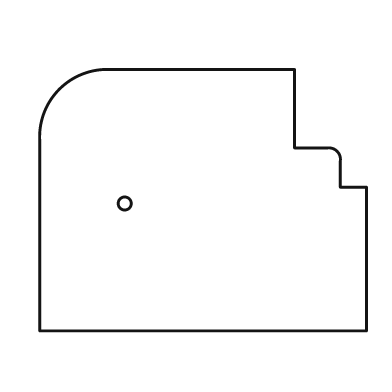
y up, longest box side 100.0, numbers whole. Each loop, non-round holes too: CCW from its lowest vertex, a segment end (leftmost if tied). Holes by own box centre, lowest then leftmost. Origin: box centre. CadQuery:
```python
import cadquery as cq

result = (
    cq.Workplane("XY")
    .moveTo(-50.0, -40.0)
    .lineTo(50.0, -40.0)
    .lineTo(50.0, 4.0)
    .lineTo(42.0, 4.0)
    .lineTo(42.0, 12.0)
    .threePointArc((41.0, 15.0), (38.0, 16.0))
    .lineTo(28.0, 16.0)
    .lineTo(28.0, 40.0)
    .lineTo(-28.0, 40.0)
    .threePointArc((-44.0, 34.0), (-50.0, 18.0))
    .close()
    .moveTo(-24.0, -1.0)
    .circle(2.0)
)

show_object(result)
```